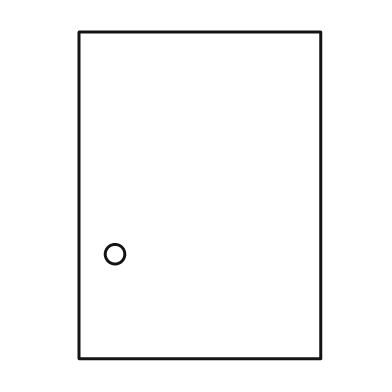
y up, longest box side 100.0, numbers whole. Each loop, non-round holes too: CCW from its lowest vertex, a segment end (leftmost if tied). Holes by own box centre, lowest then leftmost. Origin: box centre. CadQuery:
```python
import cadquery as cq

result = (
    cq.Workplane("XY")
    .moveTo(-37.0, -50.0)
    .lineTo(37.0, -50.0)
    .lineTo(37.0, 50.0)
    .lineTo(-37.0, 50.0)
    .close()
    .moveTo(-26.0, -18.0)
    .circle(3.0)
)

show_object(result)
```